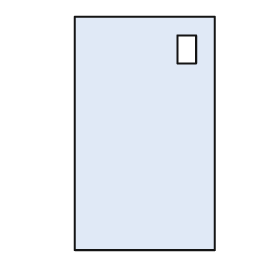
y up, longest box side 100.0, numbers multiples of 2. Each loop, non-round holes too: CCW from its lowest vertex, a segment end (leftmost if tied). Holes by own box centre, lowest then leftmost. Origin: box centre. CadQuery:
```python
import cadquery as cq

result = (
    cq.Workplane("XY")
    .moveTo(-30.0, -50.0)
    .lineTo(30.0, -50.0)
    .lineTo(30.0, 50.0)
    .lineTo(-30.0, 50.0)
    .close()
    .moveTo(14.0, 30.0)
    .lineTo(22.0, 30.0)
    .lineTo(22.0, 42.0)
    .lineTo(14.0, 42.0)
    .close()
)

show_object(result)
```